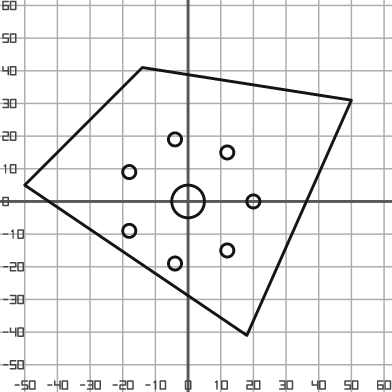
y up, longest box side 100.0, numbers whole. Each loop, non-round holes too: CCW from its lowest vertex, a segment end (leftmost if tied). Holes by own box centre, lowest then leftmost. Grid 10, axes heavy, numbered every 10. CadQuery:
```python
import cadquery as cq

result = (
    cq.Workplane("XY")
    .moveTo(18.0, -41.0)
    .lineTo(50.0, 31.0)
    .lineTo(-14.0, 41.0)
    .lineTo(-50.0, 5.0)
    .close()
    .moveTo(-4.0, -19.0)
    .circle(2.0)
    .moveTo(12.0, -15.0)
    .circle(2.0)
    .moveTo(-18.0, -9.0)
    .circle(2.0)
    .moveTo(0.0, 0.0)
    .circle(5.0)
    .moveTo(20.0, 0.0)
    .circle(2.0)
    .moveTo(-18.0, 9.0)
    .circle(2.0)
    .moveTo(12.0, 15.0)
    .circle(2.0)
    .moveTo(-4.0, 19.0)
    .circle(2.0)
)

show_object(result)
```